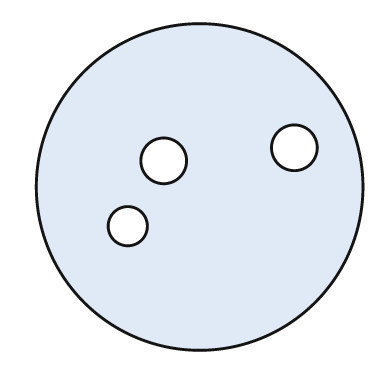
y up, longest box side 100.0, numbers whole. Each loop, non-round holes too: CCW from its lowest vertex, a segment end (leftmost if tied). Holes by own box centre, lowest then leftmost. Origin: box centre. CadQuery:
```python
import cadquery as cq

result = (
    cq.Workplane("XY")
    .moveTo(0.0, 0.0)
    .circle(50.0)
    .moveTo(-22.0, -12.0)
    .circle(6.0)
    .moveTo(-11.0, 8.0)
    .circle(7.0)
    .moveTo(29.0, 12.0)
    .circle(7.0)
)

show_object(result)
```